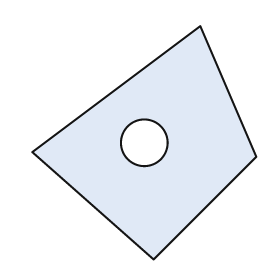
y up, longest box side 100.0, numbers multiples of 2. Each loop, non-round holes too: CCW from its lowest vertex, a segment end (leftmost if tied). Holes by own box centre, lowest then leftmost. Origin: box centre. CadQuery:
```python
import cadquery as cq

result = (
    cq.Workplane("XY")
    .moveTo(4.0, -50.0)
    .lineTo(48.0, -6.0)
    .lineTo(24.0, 50.0)
    .lineTo(-48.0, -4.0)
    .close()
    .moveTo(0.0, 0.0)
    .circle(10.0)
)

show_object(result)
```